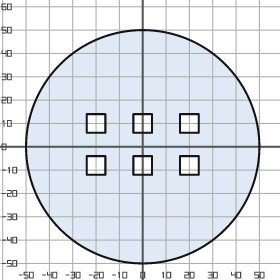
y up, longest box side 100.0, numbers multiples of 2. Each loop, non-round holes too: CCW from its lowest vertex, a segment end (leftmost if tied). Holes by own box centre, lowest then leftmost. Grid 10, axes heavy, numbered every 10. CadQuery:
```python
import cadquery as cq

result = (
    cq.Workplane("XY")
    .moveTo(0.0, 0.0)
    .circle(50.0)
    .moveTo(-24.0, -12.0)
    .lineTo(-16.0, -12.0)
    .lineTo(-16.0, -4.0)
    .lineTo(-24.0, -4.0)
    .close()
    .moveTo(-4.0, -12.0)
    .lineTo(4.0, -12.0)
    .lineTo(4.0, -4.0)
    .lineTo(-4.0, -4.0)
    .close()
    .moveTo(16.0, -12.0)
    .lineTo(24.0, -12.0)
    .lineTo(24.0, -4.0)
    .lineTo(16.0, -4.0)
    .close()
    .moveTo(-24.0, 6.0)
    .lineTo(-16.0, 6.0)
    .lineTo(-16.0, 14.0)
    .lineTo(-24.0, 14.0)
    .close()
    .moveTo(-4.0, 6.0)
    .lineTo(4.0, 6.0)
    .lineTo(4.0, 14.0)
    .lineTo(-4.0, 14.0)
    .close()
    .moveTo(16.0, 6.0)
    .lineTo(24.0, 6.0)
    .lineTo(24.0, 14.0)
    .lineTo(16.0, 14.0)
    .close()
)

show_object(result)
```